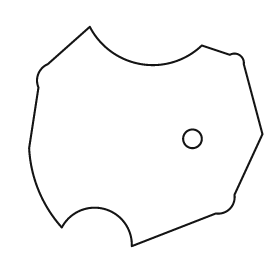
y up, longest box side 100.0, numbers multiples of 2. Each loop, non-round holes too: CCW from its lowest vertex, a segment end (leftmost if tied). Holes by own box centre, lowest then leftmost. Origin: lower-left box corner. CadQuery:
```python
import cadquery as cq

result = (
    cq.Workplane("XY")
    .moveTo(44.0, 0.0)
    .lineTo(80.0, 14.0)
    .threePointArc((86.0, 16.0), (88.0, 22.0))
    .lineTo(100.0, 48.0)
    .lineTo(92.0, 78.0)
    .threePointArc((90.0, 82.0), (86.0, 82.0))
    .lineTo(74.0, 86.0)
    .threePointArc((48.0, 78.0), (26.0, 94.0))
    .lineTo(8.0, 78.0)
    .threePointArc((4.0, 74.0), (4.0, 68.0))
    .lineTo(0.0, 42.0)
    .threePointArc((4.0, 24.0), (14.0, 8.0))
    .threePointArc((32.0, 16.0), (44.0, 0.0))
    .close()
    .moveTo(70.0, 46.0)
    .circle(4.0)
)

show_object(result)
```